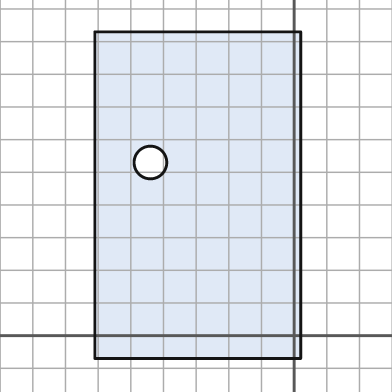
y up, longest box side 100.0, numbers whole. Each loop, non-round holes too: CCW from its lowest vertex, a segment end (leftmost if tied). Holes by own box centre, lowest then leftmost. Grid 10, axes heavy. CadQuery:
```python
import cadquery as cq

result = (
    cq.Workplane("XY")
    .moveTo(-61.0, -7.0)
    .lineTo(2.0, -7.0)
    .lineTo(2.0, 93.0)
    .lineTo(-61.0, 93.0)
    .close()
    .moveTo(-44.0, 53.0)
    .circle(5.0)
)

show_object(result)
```